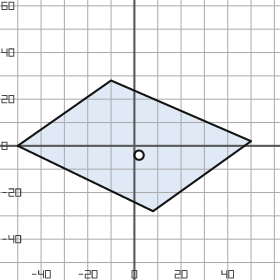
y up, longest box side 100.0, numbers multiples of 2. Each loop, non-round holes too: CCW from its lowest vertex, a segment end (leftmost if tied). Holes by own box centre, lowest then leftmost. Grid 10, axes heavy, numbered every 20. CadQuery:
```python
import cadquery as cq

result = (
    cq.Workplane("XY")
    .moveTo(8.0, -28.0)
    .lineTo(50.0, 2.0)
    .lineTo(-10.0, 28.0)
    .lineTo(-50.0, 0.0)
    .close()
    .moveTo(2.0, -4.0)
    .circle(2.0)
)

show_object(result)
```